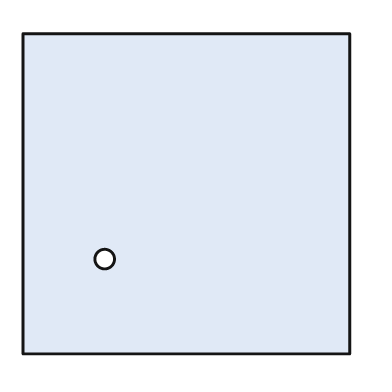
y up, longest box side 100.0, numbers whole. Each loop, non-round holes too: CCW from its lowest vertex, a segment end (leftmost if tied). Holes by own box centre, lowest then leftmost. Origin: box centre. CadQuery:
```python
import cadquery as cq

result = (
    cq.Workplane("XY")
    .moveTo(-50.0, -49.0)
    .lineTo(50.0, -49.0)
    .lineTo(50.0, 49.0)
    .lineTo(-50.0, 49.0)
    .close()
    .moveTo(-25.0, -20.0)
    .circle(3.0)
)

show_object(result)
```